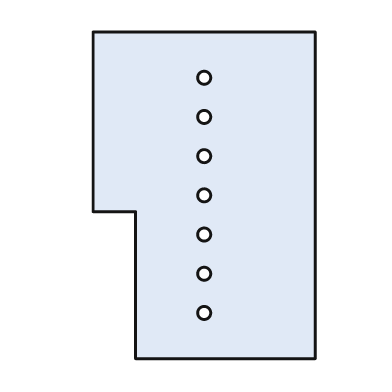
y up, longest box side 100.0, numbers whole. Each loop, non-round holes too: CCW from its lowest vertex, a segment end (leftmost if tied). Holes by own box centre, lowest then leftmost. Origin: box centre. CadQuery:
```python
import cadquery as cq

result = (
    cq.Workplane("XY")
    .moveTo(-21.0, -50.0)
    .lineTo(34.0, -50.0)
    .lineTo(34.0, 50.0)
    .lineTo(-34.0, 50.0)
    .lineTo(-34.0, -5.0)
    .lineTo(-21.0, -5.0)
    .close()
    .moveTo(0.0, -36.0)
    .circle(2.0)
    .moveTo(0.0, -24.0)
    .circle(2.0)
    .moveTo(0.0, -12.0)
    .circle(2.0)
    .moveTo(0.0, 0.0)
    .circle(2.0)
    .moveTo(0.0, 12.0)
    .circle(2.0)
    .moveTo(0.0, 24.0)
    .circle(2.0)
    .moveTo(0.0, 36.0)
    .circle(2.0)
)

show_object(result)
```